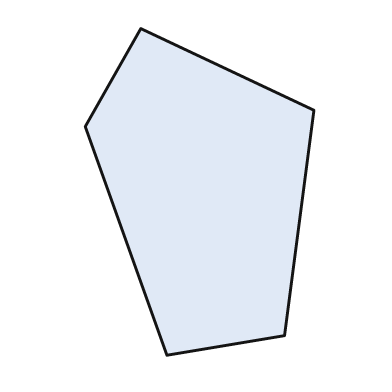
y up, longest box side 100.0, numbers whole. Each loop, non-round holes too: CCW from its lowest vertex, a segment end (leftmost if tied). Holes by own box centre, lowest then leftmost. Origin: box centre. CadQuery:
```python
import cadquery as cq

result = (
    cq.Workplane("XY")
    .moveTo(-10.0, -50.0)
    .lineTo(26.0, -44.0)
    .lineTo(35.0, 25.0)
    .lineTo(-18.0, 50.0)
    .lineTo(-35.0, 20.0)
    .close()
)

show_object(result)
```